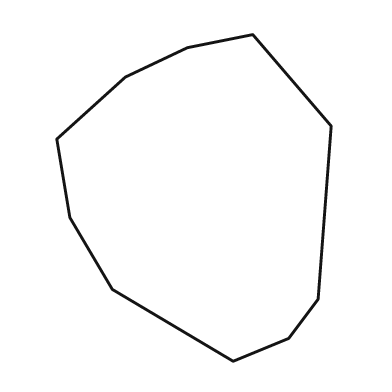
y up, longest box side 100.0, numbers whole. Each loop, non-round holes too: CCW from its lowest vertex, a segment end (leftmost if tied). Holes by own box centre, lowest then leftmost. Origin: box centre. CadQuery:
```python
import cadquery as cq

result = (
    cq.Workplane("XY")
    .moveTo(12.0, -50.0)
    .lineTo(29.0, -43.0)
    .lineTo(38.0, -31.0)
    .lineTo(42.0, 22.0)
    .lineTo(18.0, 50.0)
    .lineTo(-2.0, 46.0)
    .lineTo(-21.0, 37.0)
    .lineTo(-42.0, 18.0)
    .lineTo(-38.0, -6.0)
    .lineTo(-25.0, -28.0)
    .close()
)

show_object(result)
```